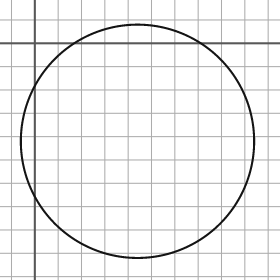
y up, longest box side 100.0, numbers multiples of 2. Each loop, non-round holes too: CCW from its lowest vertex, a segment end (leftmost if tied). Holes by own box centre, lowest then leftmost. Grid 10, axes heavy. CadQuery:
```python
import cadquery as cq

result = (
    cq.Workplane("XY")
    .moveTo(44.0, -42.0)
    .circle(50.0)
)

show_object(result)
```